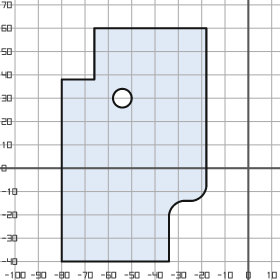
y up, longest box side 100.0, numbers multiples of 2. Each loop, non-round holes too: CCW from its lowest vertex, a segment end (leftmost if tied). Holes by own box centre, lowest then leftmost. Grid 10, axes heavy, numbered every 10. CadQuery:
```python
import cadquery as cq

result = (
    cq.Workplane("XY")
    .moveTo(-80.0, -40.0)
    .lineTo(-34.0, -40.0)
    .lineTo(-34.0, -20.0)
    .threePointArc((-32.0, -16.0), (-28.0, -14.0))
    .lineTo(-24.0, -14.0)
    .threePointArc((-20.0, -12.0), (-18.0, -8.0))
    .lineTo(-18.0, 60.0)
    .lineTo(-66.0, 60.0)
    .lineTo(-66.0, 38.0)
    .lineTo(-80.0, 38.0)
    .close()
    .moveTo(-54.0, 30.0)
    .circle(4.0)
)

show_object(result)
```